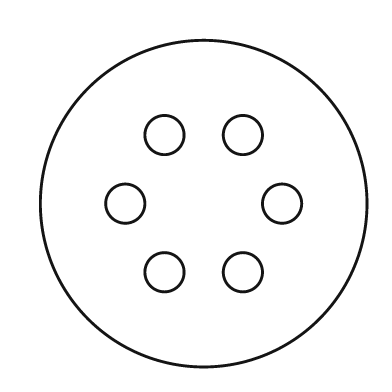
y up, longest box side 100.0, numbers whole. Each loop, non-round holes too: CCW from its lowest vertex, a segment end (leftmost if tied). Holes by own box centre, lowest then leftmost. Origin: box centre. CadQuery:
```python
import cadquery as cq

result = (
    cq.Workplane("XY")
    .moveTo(0.0, 0.0)
    .circle(50.0)
    .moveTo(-12.0, -21.0)
    .circle(6.0)
    .moveTo(12.0, -21.0)
    .circle(6.0)
    .moveTo(-24.0, 0.0)
    .circle(6.0)
    .moveTo(24.0, 0.0)
    .circle(6.0)
    .moveTo(-12.0, 21.0)
    .circle(6.0)
    .moveTo(12.0, 21.0)
    .circle(6.0)
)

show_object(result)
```